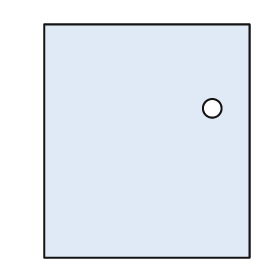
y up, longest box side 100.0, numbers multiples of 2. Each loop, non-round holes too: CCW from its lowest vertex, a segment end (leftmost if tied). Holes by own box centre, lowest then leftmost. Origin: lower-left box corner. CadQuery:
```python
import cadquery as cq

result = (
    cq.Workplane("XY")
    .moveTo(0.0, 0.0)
    .lineTo(88.0, 0.0)
    .lineTo(88.0, 100.0)
    .lineTo(0.0, 100.0)
    .close()
    .moveTo(72.0, 64.0)
    .circle(4.0)
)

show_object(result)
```